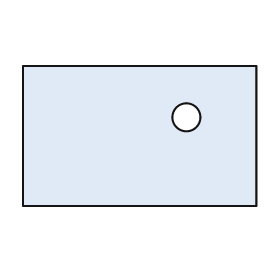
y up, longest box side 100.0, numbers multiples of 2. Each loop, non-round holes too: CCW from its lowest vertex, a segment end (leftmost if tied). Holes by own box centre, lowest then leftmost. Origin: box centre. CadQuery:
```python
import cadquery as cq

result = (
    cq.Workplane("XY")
    .moveTo(-50.0, -30.0)
    .lineTo(50.0, -30.0)
    .lineTo(50.0, 30.0)
    .lineTo(-50.0, 30.0)
    .close()
    .moveTo(20.0, 8.0)
    .circle(6.0)
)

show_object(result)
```